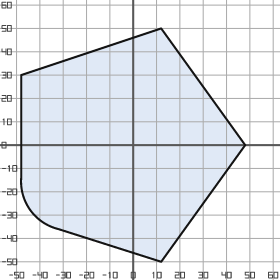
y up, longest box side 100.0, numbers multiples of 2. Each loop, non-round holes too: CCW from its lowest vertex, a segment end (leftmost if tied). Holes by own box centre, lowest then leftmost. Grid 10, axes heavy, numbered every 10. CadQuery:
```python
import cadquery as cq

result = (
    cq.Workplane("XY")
    .moveTo(12.0, -50.0)
    .lineTo(48.0, 0.0)
    .lineTo(12.0, 50.0)
    .lineTo(-48.0, 30.0)
    .lineTo(-48.0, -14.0)
    .threePointArc((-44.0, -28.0), (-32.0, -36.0))
    .close()
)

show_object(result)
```